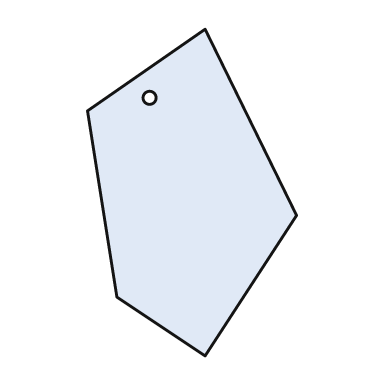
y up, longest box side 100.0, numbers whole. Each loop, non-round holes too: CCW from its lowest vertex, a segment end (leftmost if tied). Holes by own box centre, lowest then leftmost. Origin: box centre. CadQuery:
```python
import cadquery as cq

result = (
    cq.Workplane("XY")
    .moveTo(4.0, -50.0)
    .lineTo(32.0, -7.0)
    .lineTo(4.0, 50.0)
    .lineTo(-32.0, 25.0)
    .lineTo(-23.0, -32.0)
    .close()
    .moveTo(-13.0, 29.0)
    .circle(2.0)
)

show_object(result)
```